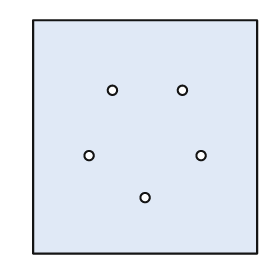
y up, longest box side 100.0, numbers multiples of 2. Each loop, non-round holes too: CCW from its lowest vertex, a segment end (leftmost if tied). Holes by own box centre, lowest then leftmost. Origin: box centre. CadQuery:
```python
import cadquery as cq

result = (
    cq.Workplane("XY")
    .moveTo(-48.0, -50.0)
    .lineTo(48.0, -50.0)
    .lineTo(48.0, 50.0)
    .lineTo(-48.0, 50.0)
    .close()
    .moveTo(0.0, -26.0)
    .circle(2.0)
    .moveTo(-24.0, -8.0)
    .circle(2.0)
    .moveTo(24.0, -8.0)
    .circle(2.0)
    .moveTo(-14.0, 20.0)
    .circle(2.0)
    .moveTo(16.0, 20.0)
    .circle(2.0)
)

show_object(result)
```